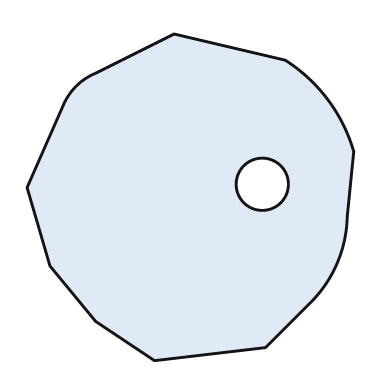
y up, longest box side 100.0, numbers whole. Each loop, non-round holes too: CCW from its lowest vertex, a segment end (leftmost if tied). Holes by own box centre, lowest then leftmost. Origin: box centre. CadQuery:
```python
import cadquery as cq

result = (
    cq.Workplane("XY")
    .moveTo(-11.0, -50.0)
    .lineTo(23.0, -46.0)
    .lineTo(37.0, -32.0)
    .threePointArc((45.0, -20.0), (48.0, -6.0))
    .lineTo(50.0, 14.0)
    .threePointArc((42.0, 30.0), (29.0, 42.0))
    .lineTo(-5.0, 50.0)
    .lineTo(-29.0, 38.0)
    .threePointArc((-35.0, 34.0), (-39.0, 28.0))
    .lineTo(-50.0, 3.0)
    .lineTo(-43.0, -21.0)
    .lineTo(-29.0, -38.0)
    .close()
    .moveTo(22.0, 4.0)
    .circle(8.0)
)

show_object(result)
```